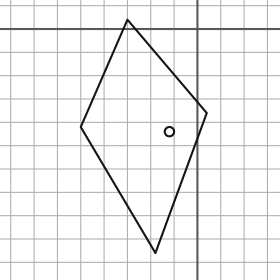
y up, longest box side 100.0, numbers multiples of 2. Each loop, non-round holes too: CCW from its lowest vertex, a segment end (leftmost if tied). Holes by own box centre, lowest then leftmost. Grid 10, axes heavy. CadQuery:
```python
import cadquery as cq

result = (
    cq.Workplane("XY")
    .moveTo(-18.0, -96.0)
    .lineTo(4.0, -36.0)
    .lineTo(-30.0, 4.0)
    .lineTo(-50.0, -42.0)
    .close()
    .moveTo(-12.0, -44.0)
    .circle(2.0)
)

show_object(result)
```